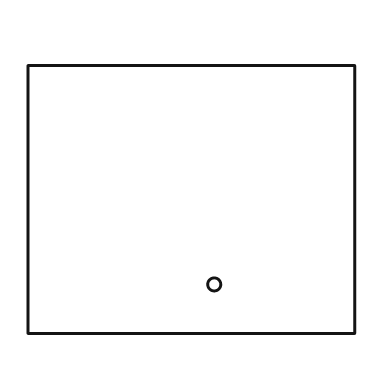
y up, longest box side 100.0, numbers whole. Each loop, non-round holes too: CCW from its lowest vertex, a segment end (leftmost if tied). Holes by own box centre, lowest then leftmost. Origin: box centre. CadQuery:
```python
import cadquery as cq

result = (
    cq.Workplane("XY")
    .moveTo(-50.0, -41.0)
    .lineTo(50.0, -41.0)
    .lineTo(50.0, 41.0)
    .lineTo(-50.0, 41.0)
    .close()
    .moveTo(7.0, -26.0)
    .circle(2.0)
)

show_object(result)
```